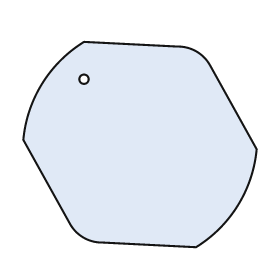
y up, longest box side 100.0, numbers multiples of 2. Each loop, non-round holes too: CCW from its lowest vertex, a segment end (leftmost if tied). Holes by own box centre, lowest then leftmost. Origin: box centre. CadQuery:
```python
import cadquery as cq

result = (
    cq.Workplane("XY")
    .moveTo(24.0, -44.0)
    .threePointArc((42.0, -26.0), (50.0, -2.0))
    .lineTo(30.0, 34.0)
    .threePointArc((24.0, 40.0), (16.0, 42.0))
    .lineTo(-24.0, 44.0)
    .threePointArc((-42.0, 26.0), (-50.0, 2.0))
    .lineTo(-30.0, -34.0)
    .threePointArc((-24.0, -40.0), (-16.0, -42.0))
    .close()
    .moveTo(-24.0, 28.0)
    .circle(2.0)
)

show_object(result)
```